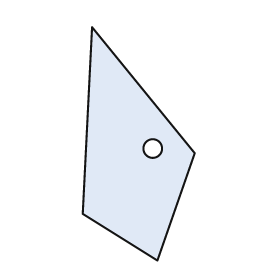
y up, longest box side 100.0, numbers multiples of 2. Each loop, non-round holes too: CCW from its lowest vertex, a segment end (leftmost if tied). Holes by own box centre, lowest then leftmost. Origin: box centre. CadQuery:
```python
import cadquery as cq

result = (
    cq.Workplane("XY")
    .moveTo(8.0, -50.0)
    .lineTo(24.0, -4.0)
    .lineTo(-20.0, 50.0)
    .lineTo(-24.0, -30.0)
    .close()
    .moveTo(6.0, -2.0)
    .circle(4.0)
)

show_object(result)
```